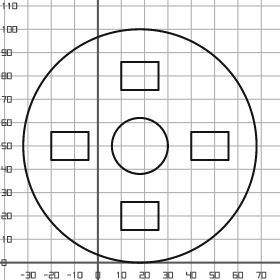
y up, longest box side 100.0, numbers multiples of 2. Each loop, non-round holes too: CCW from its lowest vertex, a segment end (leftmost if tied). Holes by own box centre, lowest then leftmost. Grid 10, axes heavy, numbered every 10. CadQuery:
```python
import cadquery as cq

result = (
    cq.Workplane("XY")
    .moveTo(18.0, 50.0)
    .circle(50.0)
    .moveTo(10.0, 14.0)
    .lineTo(26.0, 14.0)
    .lineTo(26.0, 26.0)
    .lineTo(10.0, 26.0)
    .close()
    .moveTo(-20.0, 44.0)
    .lineTo(-4.0, 44.0)
    .lineTo(-4.0, 56.0)
    .lineTo(-20.0, 56.0)
    .close()
    .moveTo(18.0, 50.0)
    .circle(12.0)
    .moveTo(40.0, 44.0)
    .lineTo(56.0, 44.0)
    .lineTo(56.0, 56.0)
    .lineTo(40.0, 56.0)
    .close()
    .moveTo(10.0, 74.0)
    .lineTo(26.0, 74.0)
    .lineTo(26.0, 86.0)
    .lineTo(10.0, 86.0)
    .close()
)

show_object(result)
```